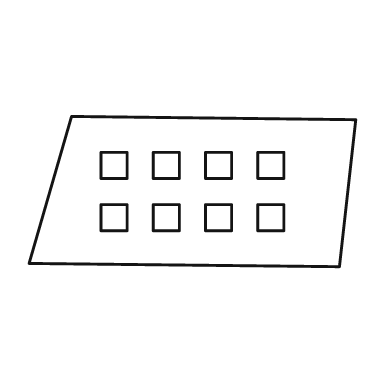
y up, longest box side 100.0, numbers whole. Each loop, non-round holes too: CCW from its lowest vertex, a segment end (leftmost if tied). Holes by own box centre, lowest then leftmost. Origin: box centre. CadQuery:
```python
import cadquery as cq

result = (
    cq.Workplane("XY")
    .moveTo(45.0, -23.0)
    .lineTo(50.0, 22.0)
    .lineTo(-37.0, 23.0)
    .lineTo(-50.0, -22.0)
    .close()
    .moveTo(-28.0, -12.0)
    .lineTo(-20.0, -12.0)
    .lineTo(-20.0, -4.0)
    .lineTo(-28.0, -4.0)
    .close()
    .moveTo(-12.0, -12.0)
    .lineTo(-4.0, -12.0)
    .lineTo(-4.0, -4.0)
    .lineTo(-12.0, -4.0)
    .close()
    .moveTo(4.0, -12.0)
    .lineTo(12.0, -12.0)
    .lineTo(12.0, -4.0)
    .lineTo(4.0, -4.0)
    .close()
    .moveTo(20.0, -12.0)
    .lineTo(28.0, -12.0)
    .lineTo(28.0, -4.0)
    .lineTo(20.0, -4.0)
    .close()
    .moveTo(-28.0, 4.0)
    .lineTo(-20.0, 4.0)
    .lineTo(-20.0, 12.0)
    .lineTo(-28.0, 12.0)
    .close()
    .moveTo(-12.0, 4.0)
    .lineTo(-4.0, 4.0)
    .lineTo(-4.0, 12.0)
    .lineTo(-12.0, 12.0)
    .close()
    .moveTo(4.0, 4.0)
    .lineTo(12.0, 4.0)
    .lineTo(12.0, 12.0)
    .lineTo(4.0, 12.0)
    .close()
    .moveTo(20.0, 4.0)
    .lineTo(28.0, 4.0)
    .lineTo(28.0, 12.0)
    .lineTo(20.0, 12.0)
    .close()
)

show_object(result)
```